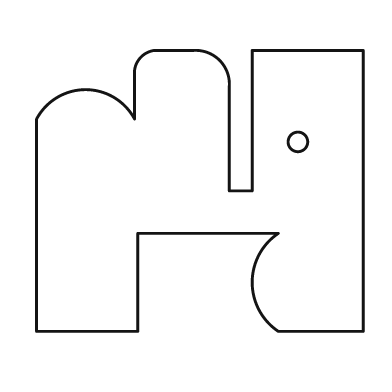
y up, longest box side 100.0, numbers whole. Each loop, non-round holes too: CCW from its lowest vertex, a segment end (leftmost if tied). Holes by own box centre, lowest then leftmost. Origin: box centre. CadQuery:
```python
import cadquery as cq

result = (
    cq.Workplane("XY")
    .moveTo(-50.0, -43.0)
    .lineTo(-19.0, -43.0)
    .lineTo(-19.0, -13.0)
    .lineTo(24.0, -13.0)
    .threePointArc((16.0, -28.0), (24.0, -43.0))
    .lineTo(50.0, -43.0)
    .lineTo(50.0, 43.0)
    .lineTo(16.0, 43.0)
    .lineTo(16.0, 0.0)
    .lineTo(9.0, 0.0)
    .lineTo(9.0, 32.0)
    .threePointArc((6.0, 40.0), (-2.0, 43.0))
    .lineTo(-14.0, 43.0)
    .threePointArc((-18.0, 41.0), (-20.0, 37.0))
    .lineTo(-20.0, 22.0)
    .threePointArc((-35.0, 31.0), (-50.0, 22.0))
    .close()
    .moveTo(30.0, 15.0)
    .circle(3.0)
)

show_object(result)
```